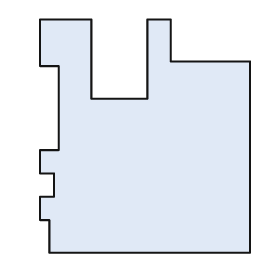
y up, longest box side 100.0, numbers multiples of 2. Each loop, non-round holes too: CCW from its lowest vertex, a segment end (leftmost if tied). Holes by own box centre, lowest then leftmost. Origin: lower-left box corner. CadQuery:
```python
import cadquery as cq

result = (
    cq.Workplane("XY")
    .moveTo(4.0, 0.0)
    .lineTo(90.0, 0.0)
    .lineTo(90.0, 82.0)
    .lineTo(56.0, 82.0)
    .lineTo(56.0, 100.0)
    .lineTo(46.0, 100.0)
    .lineTo(46.0, 66.0)
    .lineTo(22.0, 66.0)
    .lineTo(22.0, 100.0)
    .lineTo(0.0, 100.0)
    .lineTo(0.0, 80.0)
    .lineTo(8.0, 80.0)
    .lineTo(8.0, 44.0)
    .lineTo(0.0, 44.0)
    .lineTo(0.0, 34.0)
    .lineTo(6.0, 34.0)
    .lineTo(6.0, 24.0)
    .lineTo(0.0, 24.0)
    .lineTo(0.0, 14.0)
    .lineTo(4.0, 14.0)
    .close()
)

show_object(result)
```